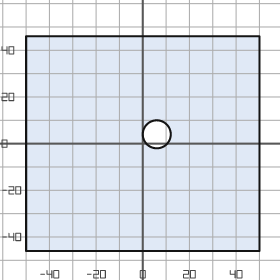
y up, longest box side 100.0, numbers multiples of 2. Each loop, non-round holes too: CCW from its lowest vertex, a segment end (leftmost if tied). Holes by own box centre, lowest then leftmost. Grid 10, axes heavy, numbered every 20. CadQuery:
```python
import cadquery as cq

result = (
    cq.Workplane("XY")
    .moveTo(-50.0, -46.0)
    .lineTo(50.0, -46.0)
    .lineTo(50.0, 46.0)
    .lineTo(-50.0, 46.0)
    .close()
    .moveTo(6.0, 4.0)
    .circle(6.0)
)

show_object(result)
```